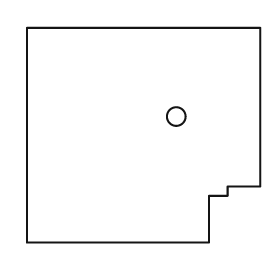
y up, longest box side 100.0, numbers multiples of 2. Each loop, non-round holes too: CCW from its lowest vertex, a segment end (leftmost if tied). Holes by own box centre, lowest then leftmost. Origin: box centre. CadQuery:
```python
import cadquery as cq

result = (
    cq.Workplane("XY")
    .moveTo(-50.0, -46.0)
    .lineTo(28.0, -46.0)
    .lineTo(28.0, -26.0)
    .lineTo(36.0, -26.0)
    .lineTo(36.0, -22.0)
    .lineTo(50.0, -22.0)
    .lineTo(50.0, 46.0)
    .lineTo(-50.0, 46.0)
    .close()
    .moveTo(14.0, 8.0)
    .circle(4.0)
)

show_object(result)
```